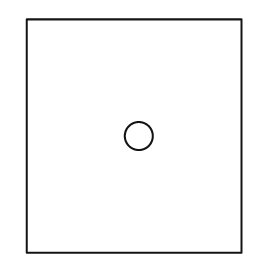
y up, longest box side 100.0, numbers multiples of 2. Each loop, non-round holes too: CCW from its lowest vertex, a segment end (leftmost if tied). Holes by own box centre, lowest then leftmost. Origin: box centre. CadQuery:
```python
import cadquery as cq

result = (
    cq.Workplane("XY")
    .moveTo(-46.0, -50.0)
    .lineTo(46.0, -50.0)
    .lineTo(46.0, 50.0)
    .lineTo(-46.0, 50.0)
    .close()
    .moveTo(2.0, 0.0)
    .circle(6.0)
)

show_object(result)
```